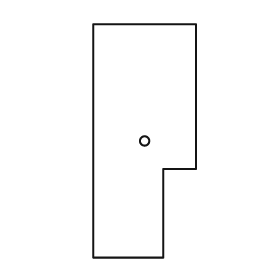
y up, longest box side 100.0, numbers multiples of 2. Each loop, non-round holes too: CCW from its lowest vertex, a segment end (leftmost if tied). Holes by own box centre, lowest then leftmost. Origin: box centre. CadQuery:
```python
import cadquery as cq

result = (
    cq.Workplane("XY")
    .moveTo(-22.0, -50.0)
    .lineTo(8.0, -50.0)
    .lineTo(8.0, -12.0)
    .lineTo(22.0, -12.0)
    .lineTo(22.0, 50.0)
    .lineTo(-22.0, 50.0)
    .close()
    .moveTo(0.0, 0.0)
    .circle(2.0)
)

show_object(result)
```